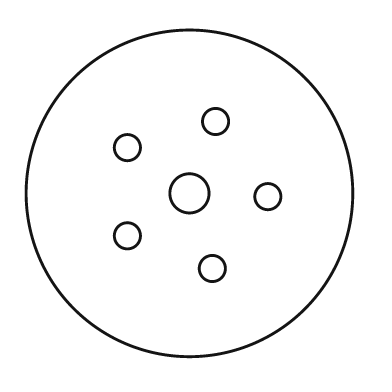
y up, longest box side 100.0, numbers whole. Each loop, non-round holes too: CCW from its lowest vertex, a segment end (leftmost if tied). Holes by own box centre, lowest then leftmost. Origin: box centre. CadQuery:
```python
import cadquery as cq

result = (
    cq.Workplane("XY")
    .moveTo(0.0, 0.0)
    .circle(50.0)
    .moveTo(7.0, -23.0)
    .circle(4.0)
    .moveTo(-19.0, -13.0)
    .circle(4.0)
    .moveTo(24.0, -1.0)
    .circle(4.0)
    .moveTo(0.0, 0.0)
    .circle(6.0)
    .moveTo(-19.0, 14.0)
    .circle(4.0)
    .moveTo(8.0, 22.0)
    .circle(4.0)
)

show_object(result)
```